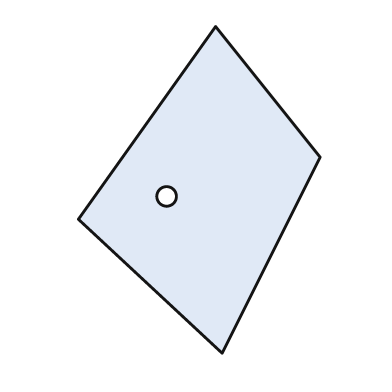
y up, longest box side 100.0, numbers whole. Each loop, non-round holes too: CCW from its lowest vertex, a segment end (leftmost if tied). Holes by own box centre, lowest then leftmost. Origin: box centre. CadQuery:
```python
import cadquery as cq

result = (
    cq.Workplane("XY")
    .moveTo(7.0, -50.0)
    .lineTo(37.0, 10.0)
    .lineTo(5.0, 50.0)
    .lineTo(-37.0, -9.0)
    .close()
    .moveTo(-10.0, -2.0)
    .circle(3.0)
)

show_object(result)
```